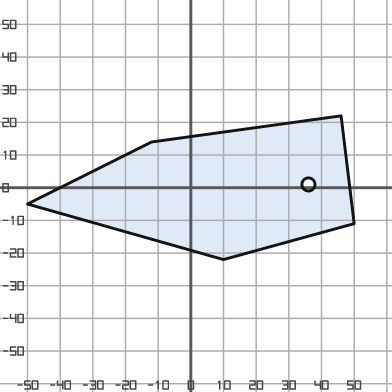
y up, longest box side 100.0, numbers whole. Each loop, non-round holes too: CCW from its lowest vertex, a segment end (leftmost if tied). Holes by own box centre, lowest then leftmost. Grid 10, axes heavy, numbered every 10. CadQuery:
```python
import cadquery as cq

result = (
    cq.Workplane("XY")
    .moveTo(10.0, -22.0)
    .lineTo(50.0, -11.0)
    .lineTo(46.0, 22.0)
    .lineTo(-12.0, 14.0)
    .lineTo(-50.0, -5.0)
    .close()
    .moveTo(36.0, 1.0)
    .circle(2.0)
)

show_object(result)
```